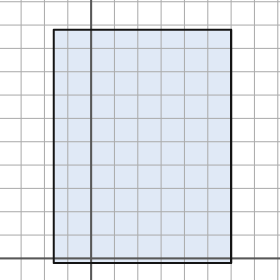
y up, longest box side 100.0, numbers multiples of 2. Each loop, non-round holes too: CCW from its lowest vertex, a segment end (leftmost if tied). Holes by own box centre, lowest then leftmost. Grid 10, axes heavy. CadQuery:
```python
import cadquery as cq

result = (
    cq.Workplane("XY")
    .moveTo(-16.0, -2.0)
    .lineTo(60.0, -2.0)
    .lineTo(60.0, 98.0)
    .lineTo(-16.0, 98.0)
    .close()
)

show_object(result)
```